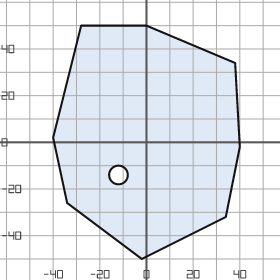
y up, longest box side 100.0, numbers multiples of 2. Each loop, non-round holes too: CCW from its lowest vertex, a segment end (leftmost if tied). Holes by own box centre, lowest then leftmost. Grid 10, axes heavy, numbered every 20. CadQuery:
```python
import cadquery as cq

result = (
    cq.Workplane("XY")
    .moveTo(-2.0, -50.0)
    .lineTo(34.0, -32.0)
    .lineTo(40.0, -2.0)
    .lineTo(38.0, 34.0)
    .lineTo(0.0, 50.0)
    .lineTo(-28.0, 50.0)
    .lineTo(-40.0, 2.0)
    .lineTo(-34.0, -26.0)
    .close()
    .moveTo(-12.0, -14.0)
    .circle(4.0)
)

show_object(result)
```